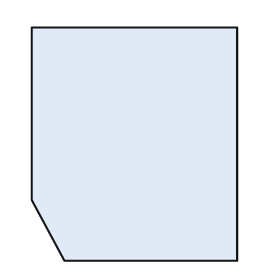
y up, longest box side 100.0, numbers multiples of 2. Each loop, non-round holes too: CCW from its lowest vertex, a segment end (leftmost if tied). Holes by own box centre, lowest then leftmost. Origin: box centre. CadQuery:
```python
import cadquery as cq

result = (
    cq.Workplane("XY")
    .moveTo(-30.0, -50.0)
    .lineTo(44.0, -50.0)
    .lineTo(44.0, 50.0)
    .lineTo(-44.0, 50.0)
    .lineTo(-44.0, -24.0)
    .close()
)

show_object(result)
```